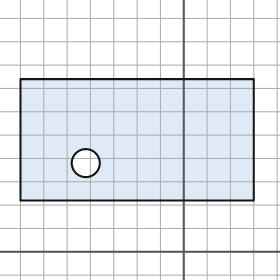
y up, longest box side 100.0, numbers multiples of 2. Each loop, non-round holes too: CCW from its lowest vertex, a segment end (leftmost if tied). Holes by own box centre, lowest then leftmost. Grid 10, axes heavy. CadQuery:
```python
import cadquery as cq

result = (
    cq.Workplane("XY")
    .moveTo(-70.0, 22.0)
    .lineTo(30.0, 22.0)
    .lineTo(30.0, 74.0)
    .lineTo(-70.0, 74.0)
    .close()
    .moveTo(-42.0, 38.0)
    .circle(6.0)
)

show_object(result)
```